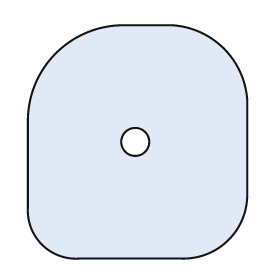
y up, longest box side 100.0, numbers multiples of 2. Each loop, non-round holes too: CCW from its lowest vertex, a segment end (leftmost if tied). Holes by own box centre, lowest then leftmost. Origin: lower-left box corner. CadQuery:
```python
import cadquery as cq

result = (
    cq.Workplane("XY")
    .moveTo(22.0, 0.0)
    .lineTo(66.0, 0.0)
    .threePointArc((86.0, 8.0), (94.0, 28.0))
    .lineTo(94.0, 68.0)
    .threePointArc((84.0, 90.0), (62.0, 100.0))
    .lineTo(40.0, 100.0)
    .threePointArc((12.0, 88.0), (0.0, 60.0))
    .lineTo(0.0, 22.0)
    .threePointArc((6.0, 6.0), (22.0, 0.0))
    .close()
    .moveTo(46.0, 50.0)
    .circle(6.0)
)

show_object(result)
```